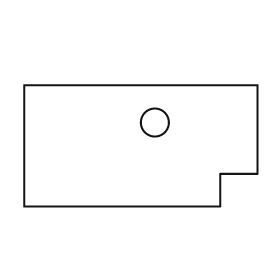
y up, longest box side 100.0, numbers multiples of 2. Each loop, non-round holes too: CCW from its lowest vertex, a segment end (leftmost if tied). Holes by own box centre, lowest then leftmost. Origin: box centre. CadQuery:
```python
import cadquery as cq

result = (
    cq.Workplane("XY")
    .moveTo(-50.0, -26.0)
    .lineTo(34.0, -26.0)
    .lineTo(34.0, -12.0)
    .lineTo(50.0, -12.0)
    .lineTo(50.0, 26.0)
    .lineTo(-50.0, 26.0)
    .close()
    .moveTo(6.0, 10.0)
    .circle(6.0)
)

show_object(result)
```